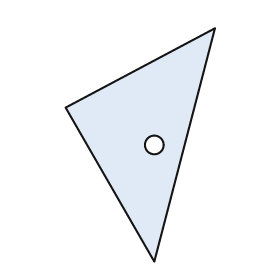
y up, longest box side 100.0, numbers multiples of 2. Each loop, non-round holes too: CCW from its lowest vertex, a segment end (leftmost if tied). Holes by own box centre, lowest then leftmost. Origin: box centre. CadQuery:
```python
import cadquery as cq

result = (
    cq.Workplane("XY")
    .moveTo(6.0, -50.0)
    .lineTo(32.0, 50.0)
    .lineTo(-32.0, 16.0)
    .close()
    .moveTo(6.0, 0.0)
    .circle(4.0)
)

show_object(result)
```